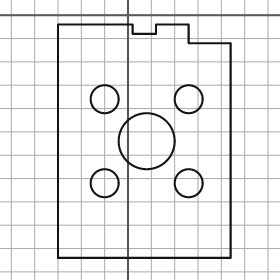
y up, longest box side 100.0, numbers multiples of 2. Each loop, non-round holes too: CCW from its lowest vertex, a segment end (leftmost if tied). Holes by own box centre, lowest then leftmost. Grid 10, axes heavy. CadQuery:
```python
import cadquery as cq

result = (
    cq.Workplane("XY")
    .moveTo(-30.0, -104.0)
    .lineTo(44.0, -104.0)
    .lineTo(44.0, -12.0)
    .lineTo(26.0, -12.0)
    .lineTo(26.0, -4.0)
    .lineTo(12.0, -4.0)
    .lineTo(12.0, -8.0)
    .lineTo(2.0, -8.0)
    .lineTo(2.0, -4.0)
    .lineTo(-30.0, -4.0)
    .close()
    .moveTo(-10.0, -72.0)
    .circle(6.0)
    .moveTo(26.0, -72.0)
    .circle(6.0)
    .moveTo(8.0, -54.0)
    .circle(12.0)
    .moveTo(-10.0, -36.0)
    .circle(6.0)
    .moveTo(26.0, -36.0)
    .circle(6.0)
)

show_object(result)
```